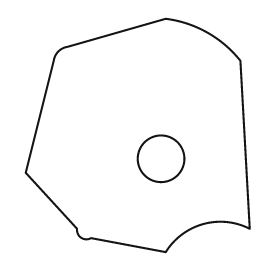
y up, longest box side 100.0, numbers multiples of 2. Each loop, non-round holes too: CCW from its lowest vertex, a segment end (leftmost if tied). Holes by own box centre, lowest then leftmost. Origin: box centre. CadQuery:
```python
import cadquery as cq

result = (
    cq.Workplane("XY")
    .moveTo(12.0, -50.0)
    .threePointArc((28.0, -38.0), (48.0, -40.0))
    .lineTo(44.0, 32.0)
    .threePointArc((30.0, 44.0), (12.0, 50.0))
    .lineTo(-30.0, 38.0)
    .threePointArc((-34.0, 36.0), (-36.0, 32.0))
    .lineTo(-48.0, -16.0)
    .lineTo(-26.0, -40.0)
    .threePointArc((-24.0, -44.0), (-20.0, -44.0))
    .close()
    .moveTo(10.0, -10.0)
    .circle(10.0)
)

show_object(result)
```